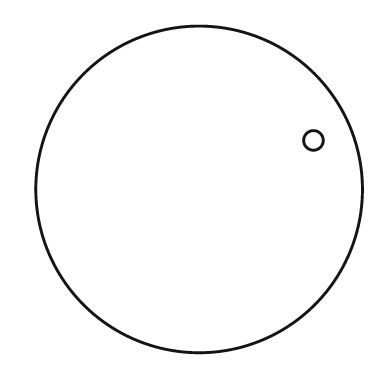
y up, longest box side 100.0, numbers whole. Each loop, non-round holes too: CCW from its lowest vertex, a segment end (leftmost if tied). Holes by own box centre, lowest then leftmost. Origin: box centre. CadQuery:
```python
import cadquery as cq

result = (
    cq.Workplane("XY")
    .moveTo(0.0, 0.0)
    .circle(50.0)
    .moveTo(35.0, 15.0)
    .circle(3.0)
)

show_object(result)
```